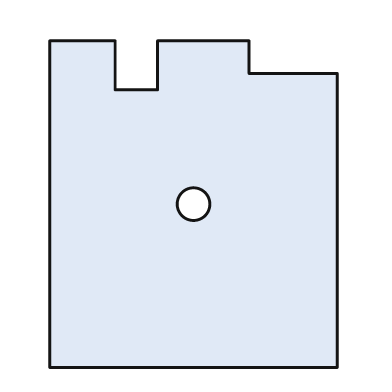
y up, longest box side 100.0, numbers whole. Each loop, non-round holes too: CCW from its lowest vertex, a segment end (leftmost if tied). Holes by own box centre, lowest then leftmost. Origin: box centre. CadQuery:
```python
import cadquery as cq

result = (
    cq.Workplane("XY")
    .moveTo(-44.0, -50.0)
    .lineTo(44.0, -50.0)
    .lineTo(44.0, 40.0)
    .lineTo(17.0, 40.0)
    .lineTo(17.0, 50.0)
    .lineTo(-11.0, 50.0)
    .lineTo(-11.0, 35.0)
    .lineTo(-24.0, 35.0)
    .lineTo(-24.0, 50.0)
    .lineTo(-44.0, 50.0)
    .close()
    .moveTo(0.0, 0.0)
    .circle(5.0)
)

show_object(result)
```